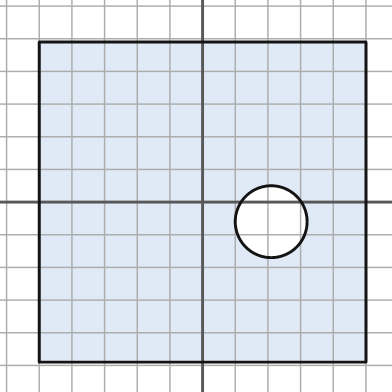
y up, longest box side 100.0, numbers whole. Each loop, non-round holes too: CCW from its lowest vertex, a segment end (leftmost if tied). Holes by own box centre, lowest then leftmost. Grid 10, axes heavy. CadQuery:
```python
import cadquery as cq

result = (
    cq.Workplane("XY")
    .moveTo(-50.0, -49.0)
    .lineTo(50.0, -49.0)
    .lineTo(50.0, 49.0)
    .lineTo(-50.0, 49.0)
    .close()
    .moveTo(21.0, -6.0)
    .circle(11.0)
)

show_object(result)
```